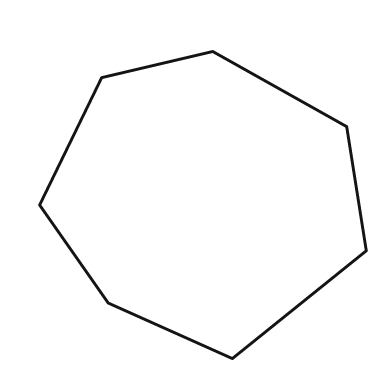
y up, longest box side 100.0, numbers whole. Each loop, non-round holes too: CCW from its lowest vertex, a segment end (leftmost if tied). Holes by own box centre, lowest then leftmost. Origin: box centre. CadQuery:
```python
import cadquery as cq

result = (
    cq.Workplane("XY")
    .moveTo(9.0, -47.0)
    .lineTo(50.0, -14.0)
    .lineTo(44.0, 24.0)
    .lineTo(3.0, 47.0)
    .lineTo(-31.0, 39.0)
    .lineTo(-50.0, 0.0)
    .lineTo(-29.0, -30.0)
    .close()
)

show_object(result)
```